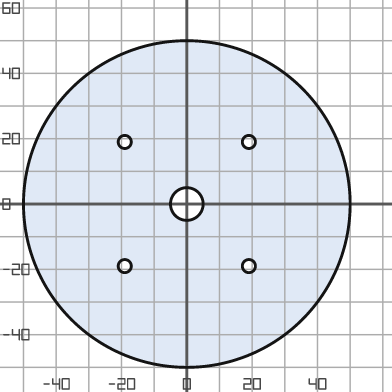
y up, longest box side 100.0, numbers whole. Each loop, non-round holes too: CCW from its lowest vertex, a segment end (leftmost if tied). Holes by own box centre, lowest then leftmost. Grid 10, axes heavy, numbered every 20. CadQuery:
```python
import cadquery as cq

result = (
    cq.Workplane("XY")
    .moveTo(0.0, 0.0)
    .circle(50.0)
    .moveTo(-19.0, -19.0)
    .circle(2.0)
    .moveTo(19.0, -19.0)
    .circle(2.0)
    .moveTo(0.0, 0.0)
    .circle(5.0)
    .moveTo(-19.0, 19.0)
    .circle(2.0)
    .moveTo(19.0, 19.0)
    .circle(2.0)
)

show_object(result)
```